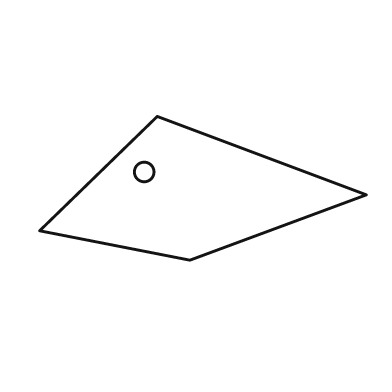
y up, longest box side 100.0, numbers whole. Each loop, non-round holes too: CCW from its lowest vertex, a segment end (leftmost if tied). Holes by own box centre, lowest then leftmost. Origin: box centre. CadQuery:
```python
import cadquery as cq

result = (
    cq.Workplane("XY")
    .moveTo(-4.0, -22.0)
    .lineTo(50.0, -2.0)
    .lineTo(-14.0, 22.0)
    .lineTo(-50.0, -13.0)
    .close()
    .moveTo(-18.0, 5.0)
    .circle(3.0)
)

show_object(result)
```